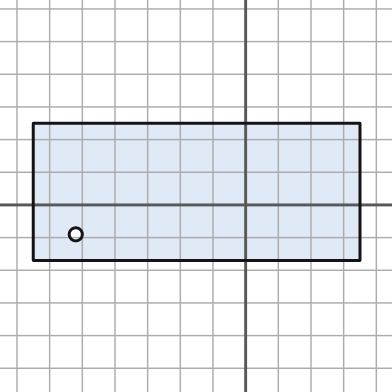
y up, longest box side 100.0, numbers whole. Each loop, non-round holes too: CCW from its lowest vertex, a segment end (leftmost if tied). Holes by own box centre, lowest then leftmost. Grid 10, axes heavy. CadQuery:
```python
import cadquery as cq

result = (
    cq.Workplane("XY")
    .moveTo(-65.0, -17.0)
    .lineTo(35.0, -17.0)
    .lineTo(35.0, 25.0)
    .lineTo(-65.0, 25.0)
    .close()
    .moveTo(-52.0, -9.0)
    .circle(2.0)
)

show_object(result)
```